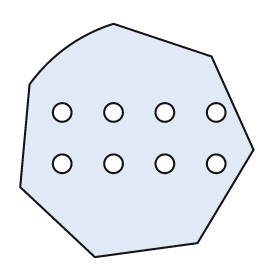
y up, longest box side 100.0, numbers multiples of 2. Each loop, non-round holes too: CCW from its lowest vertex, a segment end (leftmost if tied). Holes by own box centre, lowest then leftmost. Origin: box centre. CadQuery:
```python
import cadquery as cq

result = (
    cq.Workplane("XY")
    .moveTo(-18.0, -50.0)
    .lineTo(26.0, -44.0)
    .lineTo(50.0, -4.0)
    .lineTo(32.0, 36.0)
    .lineTo(-10.0, 50.0)
    .threePointArc((-30.0, 40.0), (-46.0, 24.0))
    .lineTo(-50.0, -20.0)
    .close()
    .moveTo(-32.0, -10.0)
    .circle(4.0)
    .moveTo(-10.0, -10.0)
    .circle(4.0)
    .moveTo(12.0, -10.0)
    .circle(4.0)
    .moveTo(34.0, -10.0)
    .circle(4.0)
    .moveTo(-32.0, 12.0)
    .circle(4.0)
    .moveTo(-10.0, 12.0)
    .circle(4.0)
    .moveTo(12.0, 12.0)
    .circle(4.0)
    .moveTo(34.0, 12.0)
    .circle(4.0)
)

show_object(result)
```